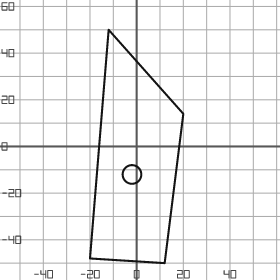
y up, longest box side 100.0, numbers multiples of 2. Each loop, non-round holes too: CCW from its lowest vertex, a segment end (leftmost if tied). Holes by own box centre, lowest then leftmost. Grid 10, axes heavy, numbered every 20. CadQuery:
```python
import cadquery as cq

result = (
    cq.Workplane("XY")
    .moveTo(12.0, -50.0)
    .lineTo(20.0, 14.0)
    .lineTo(-12.0, 50.0)
    .lineTo(-20.0, -48.0)
    .close()
    .moveTo(-2.0, -12.0)
    .circle(4.0)
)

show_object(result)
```